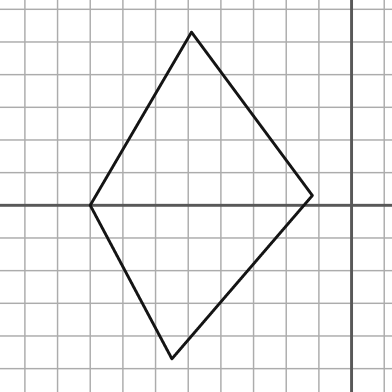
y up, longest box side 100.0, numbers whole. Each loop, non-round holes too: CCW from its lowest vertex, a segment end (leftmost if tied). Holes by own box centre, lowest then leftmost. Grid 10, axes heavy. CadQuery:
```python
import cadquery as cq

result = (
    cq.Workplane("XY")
    .moveTo(-55.0, -47.0)
    .lineTo(-12.0, 3.0)
    .lineTo(-49.0, 53.0)
    .lineTo(-80.0, 0.0)
    .close()
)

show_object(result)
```